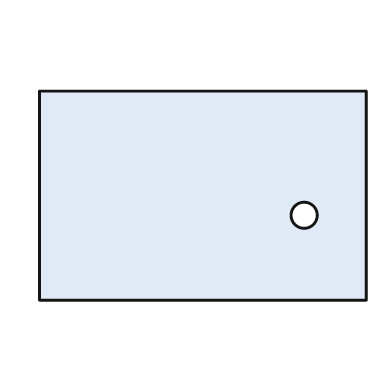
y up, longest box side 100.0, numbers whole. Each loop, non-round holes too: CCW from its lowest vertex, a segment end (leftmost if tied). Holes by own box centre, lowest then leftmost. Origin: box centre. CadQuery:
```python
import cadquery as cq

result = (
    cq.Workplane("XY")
    .moveTo(-50.0, -32.0)
    .lineTo(50.0, -32.0)
    .lineTo(50.0, 32.0)
    .lineTo(-50.0, 32.0)
    .close()
    .moveTo(31.0, -6.0)
    .circle(4.0)
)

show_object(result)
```